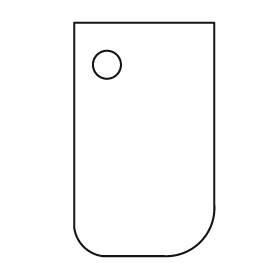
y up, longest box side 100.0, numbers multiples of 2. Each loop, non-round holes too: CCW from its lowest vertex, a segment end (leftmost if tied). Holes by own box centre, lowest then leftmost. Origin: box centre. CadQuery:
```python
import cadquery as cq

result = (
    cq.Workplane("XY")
    .moveTo(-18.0, -50.0)
    .lineTo(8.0, -50.0)
    .threePointArc((24.0, -44.0), (30.0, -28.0))
    .lineTo(30.0, 50.0)
    .lineTo(-30.0, 50.0)
    .lineTo(-30.0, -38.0)
    .threePointArc((-26.0, -46.0), (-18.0, -50.0))
    .close()
    .moveTo(-16.0, 32.0)
    .circle(6.0)
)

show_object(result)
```